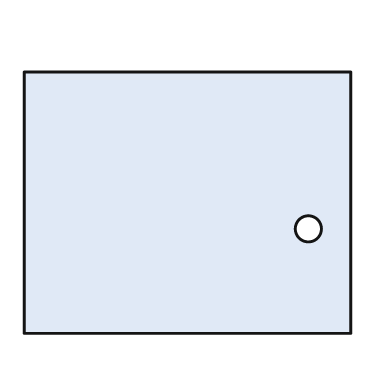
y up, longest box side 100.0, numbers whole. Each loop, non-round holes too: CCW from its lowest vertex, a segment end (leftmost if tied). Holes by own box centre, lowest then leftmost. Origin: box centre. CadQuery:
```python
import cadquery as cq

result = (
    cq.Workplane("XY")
    .moveTo(-50.0, -40.0)
    .lineTo(50.0, -40.0)
    .lineTo(50.0, 40.0)
    .lineTo(-50.0, 40.0)
    .close()
    .moveTo(37.0, -8.0)
    .circle(4.0)
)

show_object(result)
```